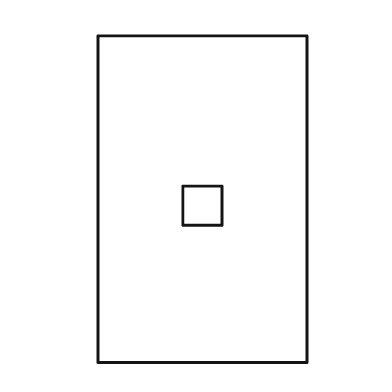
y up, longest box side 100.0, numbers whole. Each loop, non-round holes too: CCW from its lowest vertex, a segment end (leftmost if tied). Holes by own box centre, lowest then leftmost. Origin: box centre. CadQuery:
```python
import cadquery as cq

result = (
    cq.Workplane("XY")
    .moveTo(-32.0, -50.0)
    .lineTo(32.0, -50.0)
    .lineTo(32.0, 50.0)
    .lineTo(-32.0, 50.0)
    .close()
    .moveTo(-6.0, -8.0)
    .lineTo(6.0, -8.0)
    .lineTo(6.0, 4.0)
    .lineTo(-6.0, 4.0)
    .close()
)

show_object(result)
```